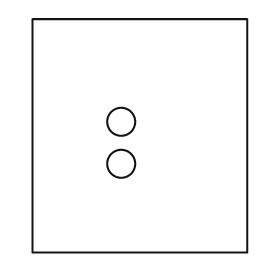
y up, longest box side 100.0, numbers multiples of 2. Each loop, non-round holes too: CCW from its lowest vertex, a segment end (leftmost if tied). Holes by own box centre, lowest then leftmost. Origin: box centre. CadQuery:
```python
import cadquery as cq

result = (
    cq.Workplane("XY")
    .moveTo(-46.0, -50.0)
    .lineTo(46.0, -50.0)
    .lineTo(46.0, 50.0)
    .lineTo(-46.0, 50.0)
    .close()
    .moveTo(-8.0, -12.0)
    .circle(6.0)
    .moveTo(-8.0, 6.0)
    .circle(6.0)
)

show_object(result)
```